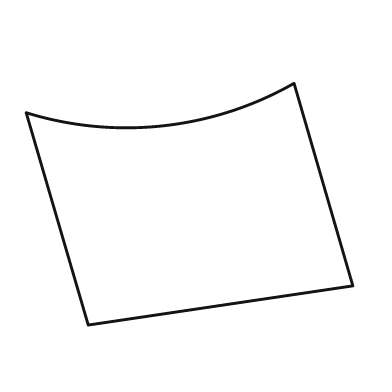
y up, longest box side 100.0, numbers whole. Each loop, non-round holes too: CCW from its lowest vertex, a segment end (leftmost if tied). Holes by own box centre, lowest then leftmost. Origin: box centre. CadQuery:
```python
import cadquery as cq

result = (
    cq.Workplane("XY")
    .moveTo(-31.0, -37.0)
    .lineTo(50.0, -25.0)
    .lineTo(32.0, 37.0)
    .threePointArc((-8.0, 24.0), (-50.0, 28.0))
    .close()
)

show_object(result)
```